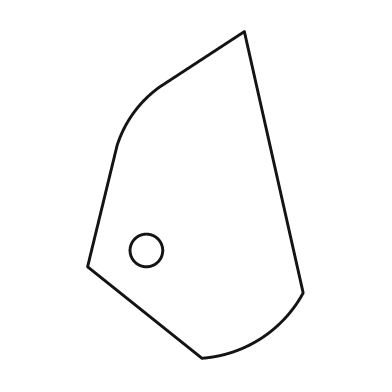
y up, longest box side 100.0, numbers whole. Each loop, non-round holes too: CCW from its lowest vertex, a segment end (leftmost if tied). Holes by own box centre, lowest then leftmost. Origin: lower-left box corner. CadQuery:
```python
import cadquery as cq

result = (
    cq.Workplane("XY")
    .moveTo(35.0, 0.0)
    .threePointArc((53.0, 6.0), (66.0, 20.0))
    .lineTo(48.0, 100.0)
    .lineTo(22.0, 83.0)
    .threePointArc((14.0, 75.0), (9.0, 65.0))
    .lineTo(0.0, 28.0)
    .close()
    .moveTo(18.0, 33.0)
    .circle(5.0)
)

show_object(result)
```